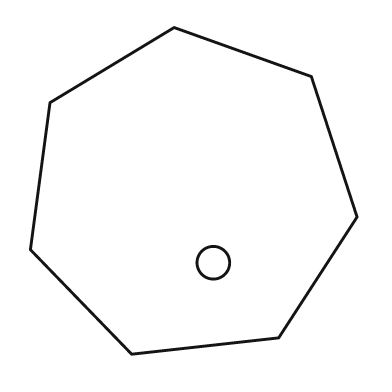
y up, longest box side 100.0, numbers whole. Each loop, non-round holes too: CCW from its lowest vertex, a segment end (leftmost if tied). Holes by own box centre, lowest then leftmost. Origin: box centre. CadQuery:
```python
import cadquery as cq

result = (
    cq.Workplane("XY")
    .moveTo(-19.0, -50.0)
    .lineTo(26.0, -45.0)
    .lineTo(50.0, -8.0)
    .lineTo(36.0, 35.0)
    .lineTo(-6.0, 50.0)
    .lineTo(-44.0, 27.0)
    .lineTo(-50.0, -18.0)
    .close()
    .moveTo(6.0, -22.0)
    .circle(5.0)
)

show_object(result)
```